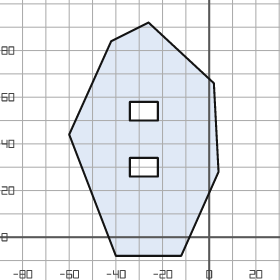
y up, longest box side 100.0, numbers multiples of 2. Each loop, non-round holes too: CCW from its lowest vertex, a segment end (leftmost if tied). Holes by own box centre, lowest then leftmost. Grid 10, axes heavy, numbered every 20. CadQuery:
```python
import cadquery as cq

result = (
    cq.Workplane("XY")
    .moveTo(-40.0, -8.0)
    .lineTo(-12.0, -8.0)
    .lineTo(4.0, 28.0)
    .lineTo(2.0, 66.0)
    .lineTo(-26.0, 92.0)
    .lineTo(-42.0, 84.0)
    .lineTo(-60.0, 44.0)
    .close()
    .moveTo(-34.0, 26.0)
    .lineTo(-22.0, 26.0)
    .lineTo(-22.0, 34.0)
    .lineTo(-34.0, 34.0)
    .close()
    .moveTo(-34.0, 50.0)
    .lineTo(-22.0, 50.0)
    .lineTo(-22.0, 58.0)
    .lineTo(-34.0, 58.0)
    .close()
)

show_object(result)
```